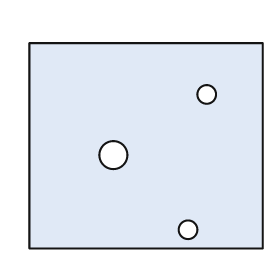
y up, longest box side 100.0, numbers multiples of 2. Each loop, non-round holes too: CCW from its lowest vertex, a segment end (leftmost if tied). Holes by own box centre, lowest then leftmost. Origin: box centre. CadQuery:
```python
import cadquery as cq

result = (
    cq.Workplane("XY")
    .moveTo(-50.0, -44.0)
    .lineTo(50.0, -44.0)
    .lineTo(50.0, 44.0)
    .lineTo(-50.0, 44.0)
    .close()
    .moveTo(18.0, -36.0)
    .circle(4.0)
    .moveTo(-14.0, -4.0)
    .circle(6.0)
    .moveTo(26.0, 22.0)
    .circle(4.0)
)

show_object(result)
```